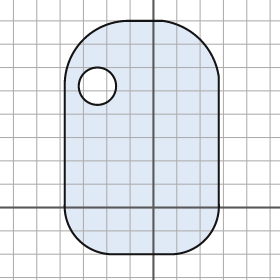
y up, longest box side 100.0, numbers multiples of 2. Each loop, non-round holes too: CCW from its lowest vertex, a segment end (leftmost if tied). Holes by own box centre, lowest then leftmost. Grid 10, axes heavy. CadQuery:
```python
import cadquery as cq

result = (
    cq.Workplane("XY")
    .moveTo(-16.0, -20.0)
    .lineTo(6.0, -20.0)
    .threePointArc((22.0, -14.0), (28.0, 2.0))
    .lineTo(28.0, 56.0)
    .threePointArc((20.0, 72.0), (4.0, 80.0))
    .lineTo(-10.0, 80.0)
    .threePointArc((-30.0, 72.0), (-38.0, 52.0))
    .lineTo(-38.0, 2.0)
    .threePointArc((-32.0, -14.0), (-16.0, -20.0))
    .close()
    .moveTo(-24.0, 52.0)
    .circle(8.0)
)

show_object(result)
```